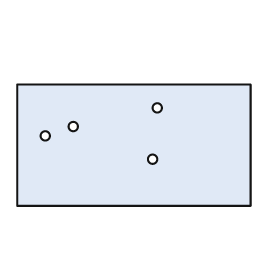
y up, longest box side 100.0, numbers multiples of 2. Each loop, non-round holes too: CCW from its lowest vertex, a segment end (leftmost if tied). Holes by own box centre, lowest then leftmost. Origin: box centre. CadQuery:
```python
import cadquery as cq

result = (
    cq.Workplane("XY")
    .moveTo(-50.0, -26.0)
    .lineTo(50.0, -26.0)
    .lineTo(50.0, 26.0)
    .lineTo(-50.0, 26.0)
    .close()
    .moveTo(8.0, -6.0)
    .circle(2.0)
    .moveTo(-38.0, 4.0)
    .circle(2.0)
    .moveTo(-26.0, 8.0)
    .circle(2.0)
    .moveTo(10.0, 16.0)
    .circle(2.0)
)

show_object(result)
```